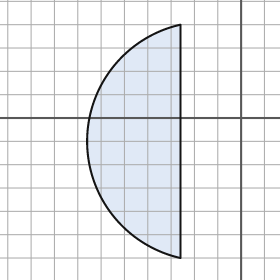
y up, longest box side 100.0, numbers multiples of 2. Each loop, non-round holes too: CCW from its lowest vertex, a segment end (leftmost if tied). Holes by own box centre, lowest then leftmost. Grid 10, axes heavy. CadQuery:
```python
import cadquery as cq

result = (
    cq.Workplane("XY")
    .moveTo(-26.0, -60.0)
    .lineTo(-26.0, 40.0)
    .threePointArc((-66.0, -10.0), (-26.0, -60.0))
    .close()
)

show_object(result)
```